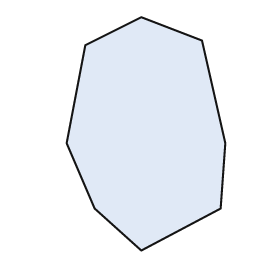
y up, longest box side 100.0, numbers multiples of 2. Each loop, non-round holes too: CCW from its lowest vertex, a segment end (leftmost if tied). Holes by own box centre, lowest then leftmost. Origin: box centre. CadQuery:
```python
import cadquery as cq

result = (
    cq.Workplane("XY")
    .moveTo(-2.0, -50.0)
    .lineTo(32.0, -32.0)
    .lineTo(34.0, -4.0)
    .lineTo(24.0, 40.0)
    .lineTo(-2.0, 50.0)
    .lineTo(-26.0, 38.0)
    .lineTo(-34.0, -4.0)
    .lineTo(-22.0, -32.0)
    .close()
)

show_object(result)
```